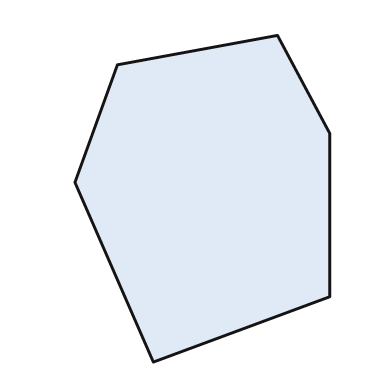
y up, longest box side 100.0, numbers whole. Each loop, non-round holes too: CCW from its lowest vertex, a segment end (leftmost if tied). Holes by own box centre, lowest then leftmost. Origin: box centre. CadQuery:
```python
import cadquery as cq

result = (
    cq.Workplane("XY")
    .moveTo(-15.0, -50.0)
    .lineTo(39.0, -30.0)
    .lineTo(39.0, 20.0)
    .lineTo(23.0, 50.0)
    .lineTo(-26.0, 41.0)
    .lineTo(-39.0, 5.0)
    .close()
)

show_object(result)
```